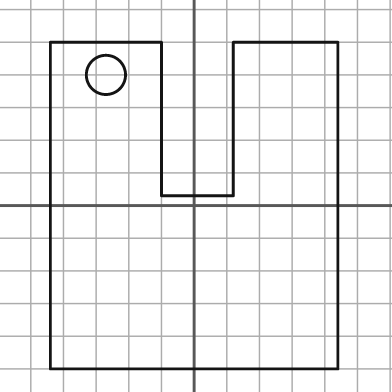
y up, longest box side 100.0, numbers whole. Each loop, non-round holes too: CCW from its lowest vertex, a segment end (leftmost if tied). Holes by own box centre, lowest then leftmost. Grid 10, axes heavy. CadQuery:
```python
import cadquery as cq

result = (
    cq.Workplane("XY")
    .moveTo(-44.0, -50.0)
    .lineTo(44.0, -50.0)
    .lineTo(44.0, 50.0)
    .lineTo(12.0, 50.0)
    .lineTo(12.0, 3.0)
    .lineTo(-10.0, 3.0)
    .lineTo(-10.0, 50.0)
    .lineTo(-44.0, 50.0)
    .close()
    .moveTo(-27.0, 40.0)
    .circle(6.0)
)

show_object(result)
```